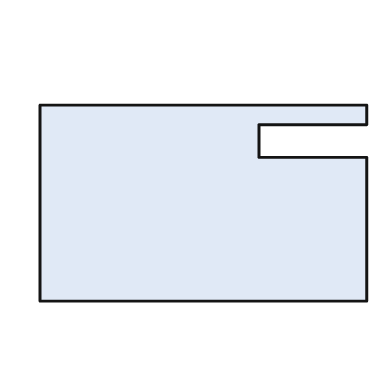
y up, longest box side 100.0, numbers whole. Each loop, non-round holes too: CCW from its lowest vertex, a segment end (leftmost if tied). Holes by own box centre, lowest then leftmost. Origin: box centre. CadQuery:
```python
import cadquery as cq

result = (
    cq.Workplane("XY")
    .moveTo(-50.0, -30.0)
    .lineTo(50.0, -30.0)
    .lineTo(50.0, 14.0)
    .lineTo(17.0, 14.0)
    .lineTo(17.0, 24.0)
    .lineTo(50.0, 24.0)
    .lineTo(50.0, 30.0)
    .lineTo(-50.0, 30.0)
    .close()
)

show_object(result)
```